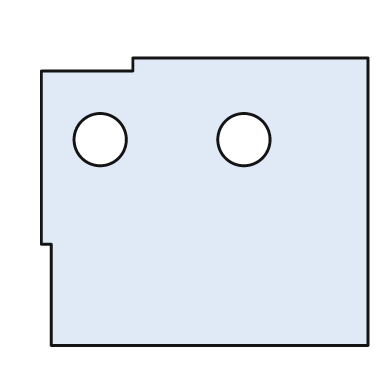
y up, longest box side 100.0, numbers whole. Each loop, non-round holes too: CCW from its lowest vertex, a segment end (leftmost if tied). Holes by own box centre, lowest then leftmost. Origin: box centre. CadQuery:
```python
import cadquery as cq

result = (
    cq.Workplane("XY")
    .moveTo(-47.0, -44.0)
    .lineTo(50.0, -44.0)
    .lineTo(50.0, 44.0)
    .lineTo(-22.0, 44.0)
    .lineTo(-22.0, 40.0)
    .lineTo(-50.0, 40.0)
    .lineTo(-50.0, -13.0)
    .lineTo(-47.0, -13.0)
    .close()
    .moveTo(-32.0, 19.0)
    .circle(8.0)
    .moveTo(12.0, 19.0)
    .circle(8.0)
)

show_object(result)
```